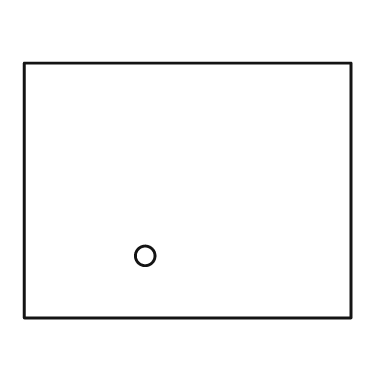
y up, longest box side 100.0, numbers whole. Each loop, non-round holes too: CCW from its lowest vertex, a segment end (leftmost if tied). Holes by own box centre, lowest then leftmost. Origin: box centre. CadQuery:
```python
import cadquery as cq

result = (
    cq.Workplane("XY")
    .moveTo(-50.0, -39.0)
    .lineTo(50.0, -39.0)
    .lineTo(50.0, 39.0)
    .lineTo(-50.0, 39.0)
    .close()
    .moveTo(-13.0, -20.0)
    .circle(3.0)
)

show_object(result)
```